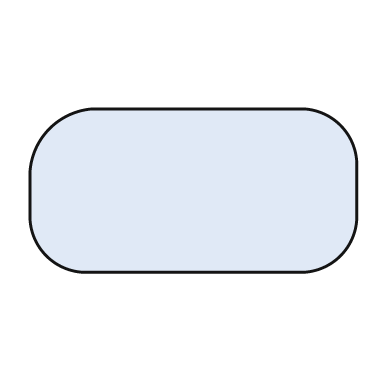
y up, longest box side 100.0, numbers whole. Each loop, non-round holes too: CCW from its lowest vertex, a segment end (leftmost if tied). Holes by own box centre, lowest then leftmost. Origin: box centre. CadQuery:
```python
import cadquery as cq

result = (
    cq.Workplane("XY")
    .moveTo(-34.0, -25.0)
    .lineTo(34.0, -25.0)
    .threePointArc((45.0, -20.0), (50.0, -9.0))
    .lineTo(50.0, 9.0)
    .threePointArc((45.0, 20.0), (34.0, 25.0))
    .lineTo(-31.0, 25.0)
    .threePointArc((-44.0, 19.0), (-50.0, 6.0))
    .lineTo(-50.0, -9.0)
    .threePointArc((-45.0, -20.0), (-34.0, -25.0))
    .close()
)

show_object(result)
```